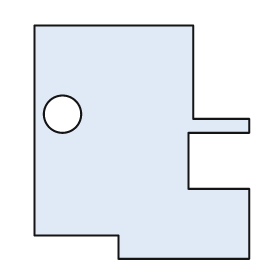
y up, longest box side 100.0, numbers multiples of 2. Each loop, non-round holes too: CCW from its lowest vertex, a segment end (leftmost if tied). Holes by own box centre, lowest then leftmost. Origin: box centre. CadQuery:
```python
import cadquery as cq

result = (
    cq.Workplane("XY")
    .moveTo(-10.0, -50.0)
    .lineTo(46.0, -50.0)
    .lineTo(46.0, -20.0)
    .lineTo(20.0, -20.0)
    .lineTo(20.0, 4.0)
    .lineTo(46.0, 4.0)
    .lineTo(46.0, 10.0)
    .lineTo(22.0, 10.0)
    .lineTo(22.0, 50.0)
    .lineTo(-46.0, 50.0)
    .lineTo(-46.0, -40.0)
    .lineTo(-10.0, -40.0)
    .close()
    .moveTo(-34.0, 12.0)
    .circle(8.0)
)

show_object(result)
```